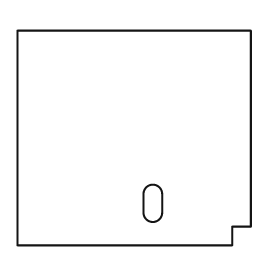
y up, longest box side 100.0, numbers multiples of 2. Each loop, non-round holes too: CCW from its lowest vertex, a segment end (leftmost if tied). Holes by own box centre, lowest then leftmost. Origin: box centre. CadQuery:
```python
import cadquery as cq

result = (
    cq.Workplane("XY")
    .moveTo(-50.0, -46.0)
    .lineTo(42.0, -46.0)
    .lineTo(42.0, -38.0)
    .lineTo(50.0, -38.0)
    .lineTo(50.0, 46.0)
    .lineTo(-50.0, 46.0)
    .close()
    .moveTo(4.0, -32.0)
    .threePointArc((8.0, -36.0), (12.0, -32.0))
    .lineTo(12.0, -24.0)
    .threePointArc((8.0, -20.0), (4.0, -24.0))
    .close()
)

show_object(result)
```